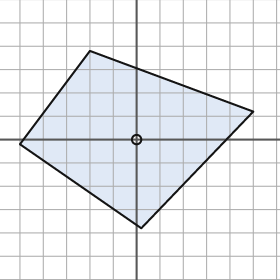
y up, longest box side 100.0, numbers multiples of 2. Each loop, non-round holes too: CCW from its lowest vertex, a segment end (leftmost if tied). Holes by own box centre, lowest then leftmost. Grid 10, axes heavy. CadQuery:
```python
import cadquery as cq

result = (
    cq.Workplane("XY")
    .moveTo(2.0, -38.0)
    .lineTo(50.0, 12.0)
    .lineTo(-20.0, 38.0)
    .lineTo(-50.0, -2.0)
    .close()
    .moveTo(0.0, 0.0)
    .circle(2.0)
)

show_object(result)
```